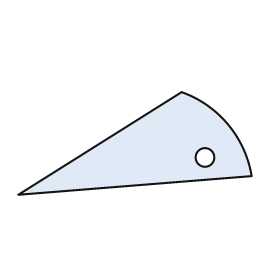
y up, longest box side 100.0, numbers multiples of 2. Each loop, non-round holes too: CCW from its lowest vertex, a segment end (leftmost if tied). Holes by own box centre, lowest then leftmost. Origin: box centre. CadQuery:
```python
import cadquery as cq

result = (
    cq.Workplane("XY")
    .moveTo(-50.0, -22.0)
    .lineTo(50.0, -14.0)
    .threePointArc((40.0, 8.0), (20.0, 22.0))
    .close()
    .moveTo(30.0, -6.0)
    .circle(4.0)
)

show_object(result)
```